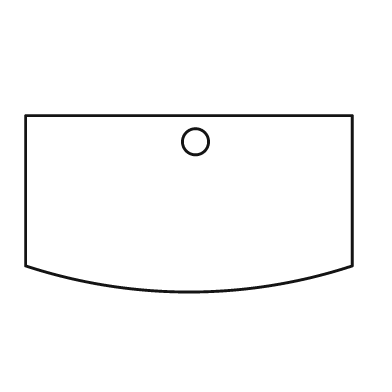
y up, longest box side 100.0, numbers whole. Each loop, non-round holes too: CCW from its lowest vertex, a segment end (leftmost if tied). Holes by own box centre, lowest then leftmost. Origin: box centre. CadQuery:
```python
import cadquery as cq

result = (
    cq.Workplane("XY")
    .moveTo(-50.0, -19.0)
    .threePointArc((0.0, -27.0), (50.0, -19.0))
    .lineTo(50.0, 27.0)
    .lineTo(-50.0, 27.0)
    .close()
    .moveTo(2.0, 19.0)
    .circle(4.0)
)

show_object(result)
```